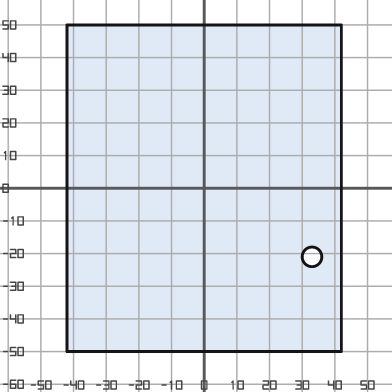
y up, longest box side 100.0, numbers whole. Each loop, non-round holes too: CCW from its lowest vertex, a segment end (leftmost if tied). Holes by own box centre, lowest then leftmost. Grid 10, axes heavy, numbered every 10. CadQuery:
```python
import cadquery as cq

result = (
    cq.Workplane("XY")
    .moveTo(-42.0, -50.0)
    .lineTo(42.0, -50.0)
    .lineTo(42.0, 50.0)
    .lineTo(-42.0, 50.0)
    .close()
    .moveTo(33.0, -21.0)
    .circle(3.0)
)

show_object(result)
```